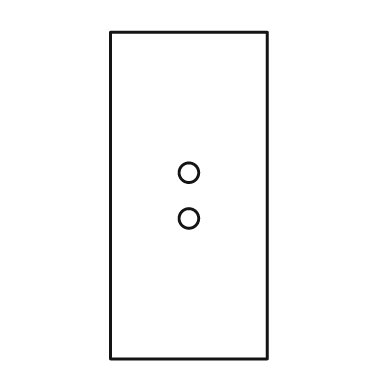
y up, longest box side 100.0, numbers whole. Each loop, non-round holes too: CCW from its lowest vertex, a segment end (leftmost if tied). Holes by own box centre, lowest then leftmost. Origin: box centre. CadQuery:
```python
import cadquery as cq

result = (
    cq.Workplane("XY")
    .moveTo(-24.0, -50.0)
    .lineTo(24.0, -50.0)
    .lineTo(24.0, 50.0)
    .lineTo(-24.0, 50.0)
    .close()
    .moveTo(0.0, -7.0)
    .circle(3.0)
    .moveTo(0.0, 7.0)
    .circle(3.0)
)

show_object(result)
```